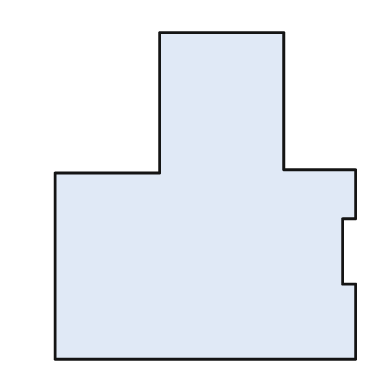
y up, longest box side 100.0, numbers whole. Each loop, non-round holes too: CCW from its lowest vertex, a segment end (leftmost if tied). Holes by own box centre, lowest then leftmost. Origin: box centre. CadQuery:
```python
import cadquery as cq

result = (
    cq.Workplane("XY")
    .moveTo(-46.0, -50.0)
    .lineTo(46.0, -50.0)
    .lineTo(46.0, -27.0)
    .lineTo(42.0, -27.0)
    .lineTo(42.0, -7.0)
    .lineTo(46.0, -7.0)
    .lineTo(46.0, 8.0)
    .lineTo(24.0, 8.0)
    .lineTo(24.0, 50.0)
    .lineTo(-14.0, 50.0)
    .lineTo(-14.0, 7.0)
    .lineTo(-46.0, 7.0)
    .close()
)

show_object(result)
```